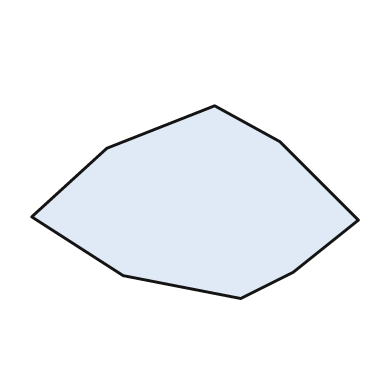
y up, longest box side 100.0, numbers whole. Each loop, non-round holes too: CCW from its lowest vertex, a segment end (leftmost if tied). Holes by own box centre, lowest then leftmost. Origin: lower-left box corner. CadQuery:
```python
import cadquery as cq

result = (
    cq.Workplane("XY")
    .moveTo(64.0, 0.0)
    .lineTo(80.0, 8.0)
    .lineTo(100.0, 24.0)
    .lineTo(76.0, 48.0)
    .lineTo(56.0, 59.0)
    .lineTo(23.0, 46.0)
    .lineTo(0.0, 25.0)
    .lineTo(28.0, 7.0)
    .close()
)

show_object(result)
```